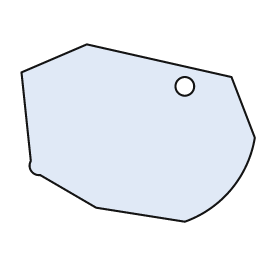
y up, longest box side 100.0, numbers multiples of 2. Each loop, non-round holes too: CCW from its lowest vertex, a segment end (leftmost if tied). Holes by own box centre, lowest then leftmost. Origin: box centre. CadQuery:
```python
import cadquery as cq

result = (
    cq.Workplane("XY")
    .moveTo(20.0, -38.0)
    .threePointArc((40.0, -24.0), (50.0, -2.0))
    .lineTo(40.0, 24.0)
    .lineTo(-22.0, 38.0)
    .lineTo(-50.0, 26.0)
    .lineTo(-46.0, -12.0)
    .threePointArc((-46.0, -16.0), (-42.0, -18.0))
    .lineTo(-18.0, -32.0)
    .close()
    .moveTo(20.0, 20.0)
    .circle(4.0)
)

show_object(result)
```